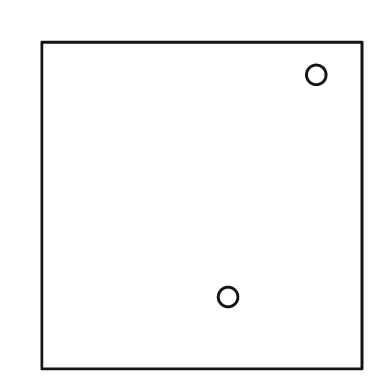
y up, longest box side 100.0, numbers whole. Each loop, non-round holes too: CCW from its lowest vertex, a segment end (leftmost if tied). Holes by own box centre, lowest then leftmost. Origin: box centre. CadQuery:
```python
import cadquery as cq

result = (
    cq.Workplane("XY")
    .moveTo(-49.0, -50.0)
    .lineTo(49.0, -50.0)
    .lineTo(49.0, 50.0)
    .lineTo(-49.0, 50.0)
    .close()
    .moveTo(8.0, -28.0)
    .circle(3.0)
    .moveTo(35.0, 40.0)
    .circle(3.0)
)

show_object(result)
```